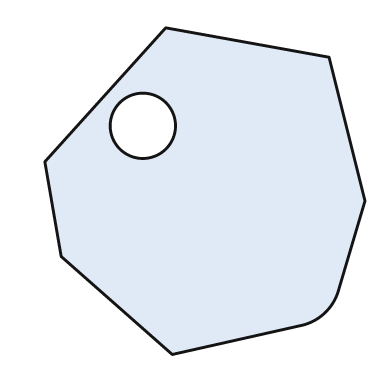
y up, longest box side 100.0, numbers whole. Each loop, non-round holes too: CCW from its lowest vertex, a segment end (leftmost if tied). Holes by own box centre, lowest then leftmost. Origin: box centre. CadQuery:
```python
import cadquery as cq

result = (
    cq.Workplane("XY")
    .moveTo(-10.0, -50.0)
    .lineTo(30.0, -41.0)
    .threePointArc((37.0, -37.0), (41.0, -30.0))
    .lineTo(49.0, -3.0)
    .lineTo(38.0, 41.0)
    .lineTo(-12.0, 50.0)
    .lineTo(-49.0, 9.0)
    .lineTo(-44.0, -20.0)
    .close()
    .moveTo(-19.0, 20.0)
    .circle(10.0)
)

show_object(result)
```